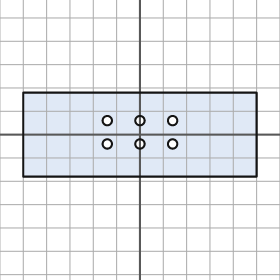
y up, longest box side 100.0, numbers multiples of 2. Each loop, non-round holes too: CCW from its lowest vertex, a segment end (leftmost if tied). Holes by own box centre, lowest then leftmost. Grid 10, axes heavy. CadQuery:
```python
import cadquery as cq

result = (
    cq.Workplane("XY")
    .moveTo(-50.0, -18.0)
    .lineTo(50.0, -18.0)
    .lineTo(50.0, 18.0)
    .lineTo(-50.0, 18.0)
    .close()
    .moveTo(-14.0, -4.0)
    .circle(2.0)
    .moveTo(0.0, -4.0)
    .circle(2.0)
    .moveTo(14.0, -4.0)
    .circle(2.0)
    .moveTo(-14.0, 6.0)
    .circle(2.0)
    .moveTo(0.0, 6.0)
    .circle(2.0)
    .moveTo(14.0, 6.0)
    .circle(2.0)
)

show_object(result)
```